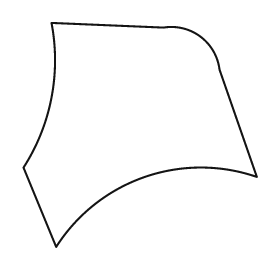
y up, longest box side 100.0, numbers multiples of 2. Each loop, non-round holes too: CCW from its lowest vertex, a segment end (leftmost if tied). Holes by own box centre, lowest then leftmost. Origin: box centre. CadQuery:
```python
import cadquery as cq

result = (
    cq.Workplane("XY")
    .moveTo(-36.0, -48.0)
    .threePointArc((2.0, -18.0), (50.0, -18.0))
    .lineTo(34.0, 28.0)
    .threePointArc((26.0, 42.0), (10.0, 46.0))
    .lineTo(-38.0, 48.0)
    .threePointArc((-38.0, 16.0), (-50.0, -14.0))
    .close()
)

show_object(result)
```